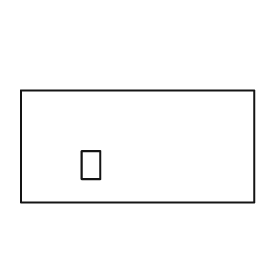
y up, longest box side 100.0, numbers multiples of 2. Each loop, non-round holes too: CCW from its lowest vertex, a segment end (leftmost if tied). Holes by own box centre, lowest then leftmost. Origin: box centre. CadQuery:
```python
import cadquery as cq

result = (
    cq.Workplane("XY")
    .moveTo(-50.0, -24.0)
    .lineTo(50.0, -24.0)
    .lineTo(50.0, 24.0)
    .lineTo(-50.0, 24.0)
    .close()
    .moveTo(-24.0, -14.0)
    .lineTo(-16.0, -14.0)
    .lineTo(-16.0, -2.0)
    .lineTo(-24.0, -2.0)
    .close()
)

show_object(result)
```